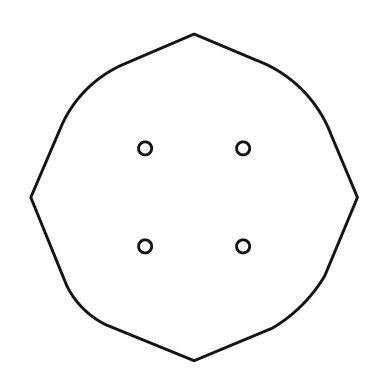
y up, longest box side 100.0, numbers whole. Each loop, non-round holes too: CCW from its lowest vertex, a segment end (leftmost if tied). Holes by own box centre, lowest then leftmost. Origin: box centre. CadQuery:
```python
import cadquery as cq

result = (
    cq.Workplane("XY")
    .moveTo(0.0, -50.0)
    .lineTo(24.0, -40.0)
    .threePointArc((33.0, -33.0), (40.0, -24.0))
    .lineTo(50.0, 0.0)
    .lineTo(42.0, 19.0)
    .threePointArc((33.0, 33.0), (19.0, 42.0))
    .lineTo(0.0, 50.0)
    .lineTo(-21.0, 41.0)
    .threePointArc((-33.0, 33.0), (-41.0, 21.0))
    .lineTo(-50.0, 0.0)
    .lineTo(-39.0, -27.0)
    .threePointArc((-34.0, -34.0), (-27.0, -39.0))
    .close()
    .moveTo(-15.0, -15.0)
    .circle(2.0)
    .moveTo(15.0, -15.0)
    .circle(2.0)
    .moveTo(-15.0, 15.0)
    .circle(2.0)
    .moveTo(15.0, 15.0)
    .circle(2.0)
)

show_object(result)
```